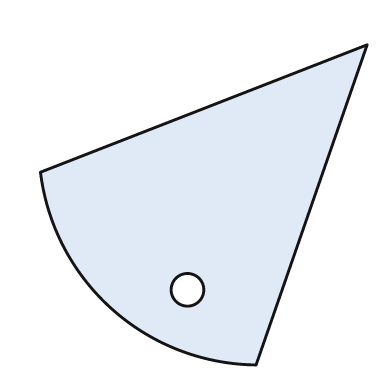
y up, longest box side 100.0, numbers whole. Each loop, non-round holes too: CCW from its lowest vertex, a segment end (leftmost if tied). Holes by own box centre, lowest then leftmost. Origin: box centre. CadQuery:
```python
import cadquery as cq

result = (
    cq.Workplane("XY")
    .moveTo(16.0, -49.0)
    .lineTo(50.0, 49.0)
    .lineTo(-50.0, 10.0)
    .threePointArc((-28.0, -32.0), (16.0, -49.0))
    .close()
    .moveTo(-5.0, -26.0)
    .circle(5.0)
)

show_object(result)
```